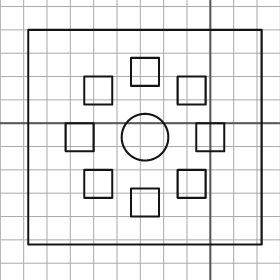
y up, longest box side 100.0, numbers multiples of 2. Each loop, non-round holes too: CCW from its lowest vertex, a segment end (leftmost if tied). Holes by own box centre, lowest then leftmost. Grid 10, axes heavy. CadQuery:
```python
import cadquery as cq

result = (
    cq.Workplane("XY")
    .moveTo(-78.0, -52.0)
    .lineTo(22.0, -52.0)
    .lineTo(22.0, 40.0)
    .lineTo(-78.0, 40.0)
    .close()
    .moveTo(-34.0, -40.0)
    .lineTo(-22.0, -40.0)
    .lineTo(-22.0, -28.0)
    .lineTo(-34.0, -28.0)
    .close()
    .moveTo(-54.0, -32.0)
    .lineTo(-42.0, -32.0)
    .lineTo(-42.0, -20.0)
    .lineTo(-54.0, -20.0)
    .close()
    .moveTo(-14.0, -32.0)
    .lineTo(-2.0, -32.0)
    .lineTo(-2.0, -20.0)
    .lineTo(-14.0, -20.0)
    .close()
    .moveTo(-62.0, -12.0)
    .lineTo(-50.0, -12.0)
    .lineTo(-50.0, 0.0)
    .lineTo(-62.0, 0.0)
    .close()
    .moveTo(-28.0, -6.0)
    .circle(10.0)
    .moveTo(-6.0, -12.0)
    .lineTo(6.0, -12.0)
    .lineTo(6.0, 0.0)
    .lineTo(-6.0, 0.0)
    .close()
    .moveTo(-54.0, 8.0)
    .lineTo(-42.0, 8.0)
    .lineTo(-42.0, 20.0)
    .lineTo(-54.0, 20.0)
    .close()
    .moveTo(-14.0, 8.0)
    .lineTo(-2.0, 8.0)
    .lineTo(-2.0, 20.0)
    .lineTo(-14.0, 20.0)
    .close()
    .moveTo(-34.0, 16.0)
    .lineTo(-22.0, 16.0)
    .lineTo(-22.0, 28.0)
    .lineTo(-34.0, 28.0)
    .close()
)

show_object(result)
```